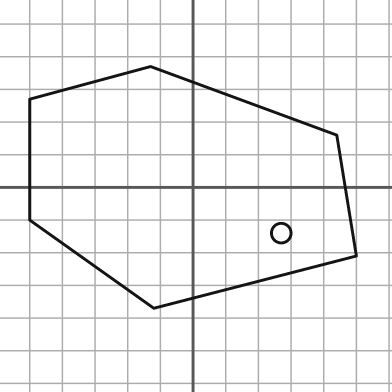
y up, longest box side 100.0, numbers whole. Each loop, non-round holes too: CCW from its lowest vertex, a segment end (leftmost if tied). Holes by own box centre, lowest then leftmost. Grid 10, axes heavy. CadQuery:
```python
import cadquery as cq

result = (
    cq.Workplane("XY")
    .moveTo(-12.0, -37.0)
    .lineTo(50.0, -21.0)
    .lineTo(44.0, 16.0)
    .lineTo(-13.0, 37.0)
    .lineTo(-50.0, 27.0)
    .lineTo(-50.0, -10.0)
    .close()
    .moveTo(27.0, -14.0)
    .circle(3.0)
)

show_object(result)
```